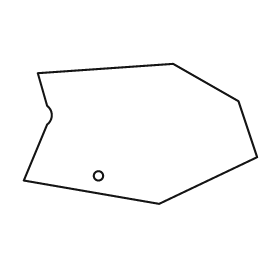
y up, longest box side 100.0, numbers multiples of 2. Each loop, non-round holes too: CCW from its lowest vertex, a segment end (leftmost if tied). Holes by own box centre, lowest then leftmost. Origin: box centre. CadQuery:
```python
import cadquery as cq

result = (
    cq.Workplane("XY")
    .moveTo(8.0, -30.0)
    .lineTo(50.0, -10.0)
    .lineTo(42.0, 14.0)
    .lineTo(14.0, 30.0)
    .lineTo(-44.0, 26.0)
    .lineTo(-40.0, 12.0)
    .threePointArc((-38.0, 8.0), (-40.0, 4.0))
    .lineTo(-50.0, -20.0)
    .close()
    .moveTo(-18.0, -18.0)
    .circle(2.0)
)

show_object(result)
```